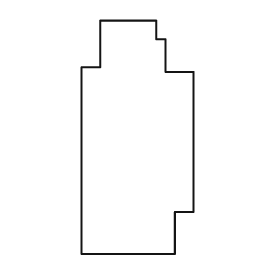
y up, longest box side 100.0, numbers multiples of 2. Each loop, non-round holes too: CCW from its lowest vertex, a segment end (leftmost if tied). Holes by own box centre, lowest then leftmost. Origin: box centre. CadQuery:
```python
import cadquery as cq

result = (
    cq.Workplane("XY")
    .moveTo(-24.0, -50.0)
    .lineTo(16.0, -50.0)
    .lineTo(16.0, -32.0)
    .lineTo(24.0, -32.0)
    .lineTo(24.0, 28.0)
    .lineTo(12.0, 28.0)
    .lineTo(12.0, 42.0)
    .lineTo(8.0, 42.0)
    .lineTo(8.0, 50.0)
    .lineTo(-16.0, 50.0)
    .lineTo(-16.0, 30.0)
    .lineTo(-24.0, 30.0)
    .close()
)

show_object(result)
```